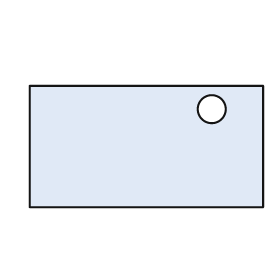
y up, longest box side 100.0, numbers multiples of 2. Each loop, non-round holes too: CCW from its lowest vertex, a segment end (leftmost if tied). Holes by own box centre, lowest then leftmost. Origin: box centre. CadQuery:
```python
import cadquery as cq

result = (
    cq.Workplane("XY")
    .moveTo(-50.0, -26.0)
    .lineTo(50.0, -26.0)
    .lineTo(50.0, 26.0)
    .lineTo(-50.0, 26.0)
    .close()
    .moveTo(28.0, 16.0)
    .circle(6.0)
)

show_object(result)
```